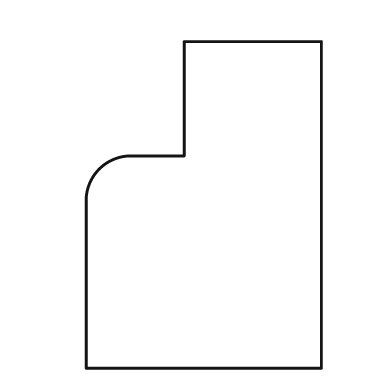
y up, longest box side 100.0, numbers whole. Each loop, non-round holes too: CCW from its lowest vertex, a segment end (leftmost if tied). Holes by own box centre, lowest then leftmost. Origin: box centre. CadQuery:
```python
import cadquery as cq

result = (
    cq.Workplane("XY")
    .moveTo(-36.0, -50.0)
    .lineTo(36.0, -50.0)
    .lineTo(36.0, 50.0)
    .lineTo(-6.0, 50.0)
    .lineTo(-6.0, 15.0)
    .lineTo(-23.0, 15.0)
    .threePointArc((-32.0, 11.0), (-36.0, 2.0))
    .close()
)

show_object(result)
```